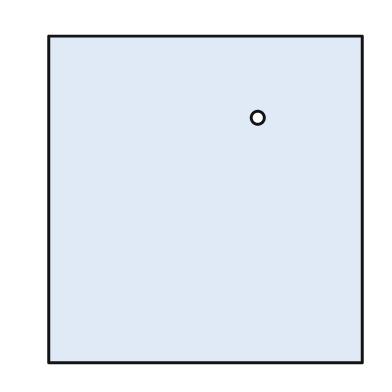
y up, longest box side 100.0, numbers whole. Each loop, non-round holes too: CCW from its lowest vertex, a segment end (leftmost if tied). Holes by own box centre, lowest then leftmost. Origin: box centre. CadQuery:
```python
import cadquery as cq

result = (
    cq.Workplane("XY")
    .moveTo(-48.0, -50.0)
    .lineTo(48.0, -50.0)
    .lineTo(48.0, 50.0)
    .lineTo(-48.0, 50.0)
    .close()
    .moveTo(16.0, 25.0)
    .circle(2.0)
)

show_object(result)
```